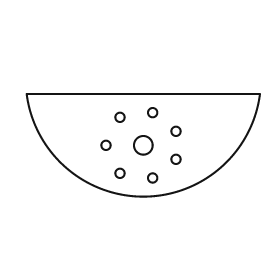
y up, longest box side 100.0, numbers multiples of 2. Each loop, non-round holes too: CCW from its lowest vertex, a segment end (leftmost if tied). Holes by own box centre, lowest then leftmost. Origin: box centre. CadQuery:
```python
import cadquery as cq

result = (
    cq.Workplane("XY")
    .moveTo(-50.0, 22.0)
    .threePointArc((0.0, -22.0), (50.0, 22.0))
    .close()
    .moveTo(4.0, -14.0)
    .circle(2.0)
    .moveTo(-10.0, -12.0)
    .circle(2.0)
    .moveTo(14.0, -6.0)
    .circle(2.0)
    .moveTo(-16.0, 0.0)
    .circle(2.0)
    .moveTo(0.0, 0.0)
    .circle(4.0)
    .moveTo(14.0, 6.0)
    .circle(2.0)
    .moveTo(-10.0, 12.0)
    .circle(2.0)
    .moveTo(4.0, 14.0)
    .circle(2.0)
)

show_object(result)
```